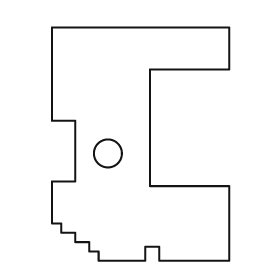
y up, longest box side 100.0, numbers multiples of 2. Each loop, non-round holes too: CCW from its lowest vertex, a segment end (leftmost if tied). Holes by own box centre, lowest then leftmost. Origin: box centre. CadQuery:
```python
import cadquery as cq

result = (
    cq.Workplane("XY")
    .moveTo(-18.0, -50.0)
    .lineTo(2.0, -50.0)
    .lineTo(2.0, -44.0)
    .lineTo(8.0, -44.0)
    .lineTo(8.0, -50.0)
    .lineTo(38.0, -50.0)
    .lineTo(38.0, -18.0)
    .lineTo(4.0, -18.0)
    .lineTo(4.0, 32.0)
    .lineTo(38.0, 32.0)
    .lineTo(38.0, 50.0)
    .lineTo(-38.0, 50.0)
    .lineTo(-38.0, 10.0)
    .lineTo(-28.0, 10.0)
    .lineTo(-28.0, -16.0)
    .lineTo(-38.0, -16.0)
    .lineTo(-38.0, -34.0)
    .lineTo(-34.0, -34.0)
    .lineTo(-34.0, -38.0)
    .lineTo(-28.0, -38.0)
    .lineTo(-28.0, -42.0)
    .lineTo(-22.0, -42.0)
    .lineTo(-22.0, -46.0)
    .lineTo(-18.0, -46.0)
    .close()
    .moveTo(-14.0, -4.0)
    .circle(6.0)
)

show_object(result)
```